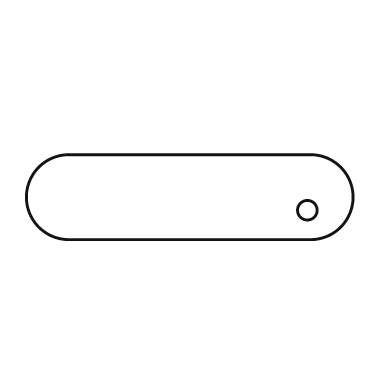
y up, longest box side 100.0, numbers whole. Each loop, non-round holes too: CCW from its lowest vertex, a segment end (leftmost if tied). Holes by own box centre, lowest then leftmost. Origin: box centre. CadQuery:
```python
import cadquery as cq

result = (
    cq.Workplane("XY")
    .moveTo(-37.0, -13.0)
    .lineTo(37.0, -13.0)
    .threePointArc((50.0, 0.0), (37.0, 13.0))
    .lineTo(-37.0, 13.0)
    .threePointArc((-50.0, 0.0), (-37.0, -13.0))
    .close()
    .moveTo(36.0, -4.0)
    .circle(3.0)
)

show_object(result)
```